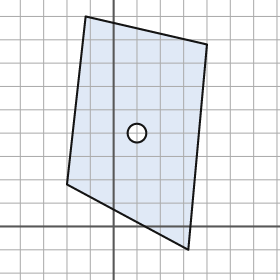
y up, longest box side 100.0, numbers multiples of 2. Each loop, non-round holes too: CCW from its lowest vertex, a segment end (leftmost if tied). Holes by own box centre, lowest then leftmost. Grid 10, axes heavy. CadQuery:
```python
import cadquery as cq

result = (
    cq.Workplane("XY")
    .moveTo(32.0, -10.0)
    .lineTo(40.0, 78.0)
    .lineTo(-12.0, 90.0)
    .lineTo(-20.0, 18.0)
    .close()
    .moveTo(10.0, 40.0)
    .circle(4.0)
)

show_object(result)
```